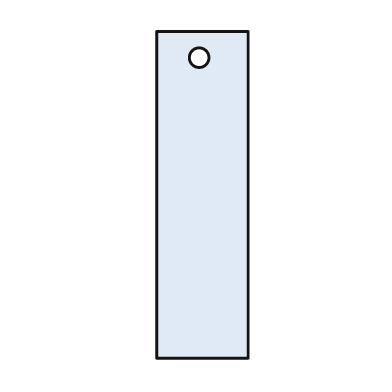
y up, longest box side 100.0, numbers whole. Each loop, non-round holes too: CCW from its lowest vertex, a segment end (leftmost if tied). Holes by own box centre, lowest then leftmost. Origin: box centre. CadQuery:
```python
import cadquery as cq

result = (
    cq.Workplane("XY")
    .moveTo(-14.0, -50.0)
    .lineTo(14.0, -50.0)
    .lineTo(14.0, 50.0)
    .lineTo(-14.0, 50.0)
    .close()
    .moveTo(-1.0, 42.0)
    .circle(3.0)
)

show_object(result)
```